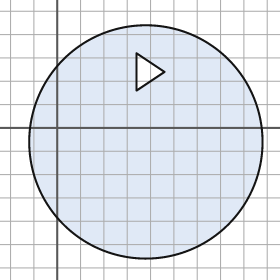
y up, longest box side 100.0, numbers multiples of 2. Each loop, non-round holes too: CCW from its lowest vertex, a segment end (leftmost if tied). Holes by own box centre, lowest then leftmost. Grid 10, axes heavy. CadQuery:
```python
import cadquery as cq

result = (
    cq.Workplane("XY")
    .moveTo(38.0, -6.0)
    .circle(50.0)
    .moveTo(34.0, 16.0)
    .lineTo(46.0, 24.0)
    .lineTo(34.0, 32.0)
    .close()
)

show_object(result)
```